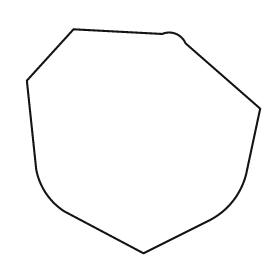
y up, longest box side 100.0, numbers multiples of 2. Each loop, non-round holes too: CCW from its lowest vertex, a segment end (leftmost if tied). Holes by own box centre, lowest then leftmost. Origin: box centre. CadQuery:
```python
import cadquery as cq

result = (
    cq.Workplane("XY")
    .moveTo(0.0, -48.0)
    .lineTo(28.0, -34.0)
    .threePointArc((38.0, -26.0), (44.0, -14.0))
    .lineTo(50.0, 14.0)
    .lineTo(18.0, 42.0)
    .threePointArc((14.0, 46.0), (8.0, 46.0))
    .lineTo(-30.0, 48.0)
    .lineTo(-50.0, 26.0)
    .lineTo(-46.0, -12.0)
    .threePointArc((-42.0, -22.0), (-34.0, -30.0))
    .close()
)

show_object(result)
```